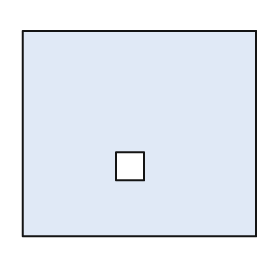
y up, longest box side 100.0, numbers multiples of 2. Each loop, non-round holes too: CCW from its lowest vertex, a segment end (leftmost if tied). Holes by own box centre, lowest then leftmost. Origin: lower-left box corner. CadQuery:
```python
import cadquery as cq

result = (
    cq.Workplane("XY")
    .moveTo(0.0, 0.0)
    .lineTo(100.0, 0.0)
    .lineTo(100.0, 88.0)
    .lineTo(0.0, 88.0)
    .close()
    .moveTo(40.0, 24.0)
    .lineTo(52.0, 24.0)
    .lineTo(52.0, 36.0)
    .lineTo(40.0, 36.0)
    .close()
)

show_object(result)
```